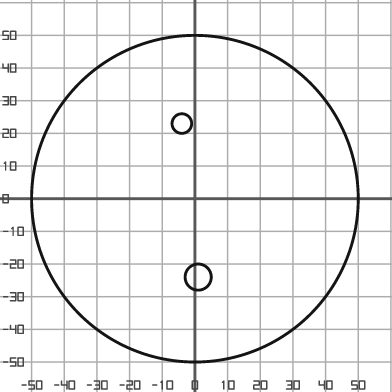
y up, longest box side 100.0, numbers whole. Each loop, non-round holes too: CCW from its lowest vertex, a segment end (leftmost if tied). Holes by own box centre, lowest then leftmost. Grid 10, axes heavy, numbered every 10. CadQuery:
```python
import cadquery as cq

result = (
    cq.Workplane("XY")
    .moveTo(0.0, 0.0)
    .circle(50.0)
    .moveTo(1.0, -24.0)
    .circle(4.0)
    .moveTo(-4.0, 23.0)
    .circle(3.0)
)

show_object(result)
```